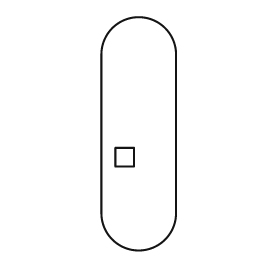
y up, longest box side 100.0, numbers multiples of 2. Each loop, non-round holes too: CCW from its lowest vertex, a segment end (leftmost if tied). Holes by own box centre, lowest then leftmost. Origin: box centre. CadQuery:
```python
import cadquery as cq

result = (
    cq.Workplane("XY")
    .moveTo(-16.0, -34.0)
    .threePointArc((0.0, -50.0), (16.0, -34.0))
    .lineTo(16.0, 34.0)
    .threePointArc((0.0, 50.0), (-16.0, 34.0))
    .close()
    .moveTo(-10.0, -14.0)
    .lineTo(-2.0, -14.0)
    .lineTo(-2.0, -6.0)
    .lineTo(-10.0, -6.0)
    .close()
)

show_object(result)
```